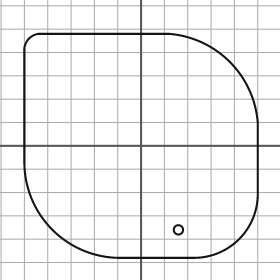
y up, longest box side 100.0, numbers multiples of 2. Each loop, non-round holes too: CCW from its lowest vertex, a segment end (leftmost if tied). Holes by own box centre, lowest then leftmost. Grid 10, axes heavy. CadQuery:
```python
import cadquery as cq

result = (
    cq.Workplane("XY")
    .moveTo(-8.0, -48.0)
    .lineTo(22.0, -48.0)
    .threePointArc((42.0, -40.0), (50.0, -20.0))
    .lineTo(50.0, 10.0)
    .threePointArc((38.0, 36.0), (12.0, 48.0))
    .lineTo(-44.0, 48.0)
    .threePointArc((-48.0, 46.0), (-50.0, 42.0))
    .lineTo(-50.0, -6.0)
    .threePointArc((-38.0, -36.0), (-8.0, -48.0))
    .close()
    .moveTo(16.0, -36.0)
    .circle(2.0)
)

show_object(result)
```